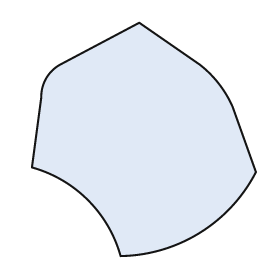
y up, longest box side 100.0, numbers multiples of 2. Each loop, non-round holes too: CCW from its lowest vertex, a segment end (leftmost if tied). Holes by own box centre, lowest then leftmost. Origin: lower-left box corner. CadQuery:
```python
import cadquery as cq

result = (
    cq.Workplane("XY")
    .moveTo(38.0, 0.0)
    .threePointArc((72.0, 10.0), (96.0, 36.0))
    .lineTo(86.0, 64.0)
    .threePointArc((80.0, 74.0), (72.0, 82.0))
    .lineTo(46.0, 100.0)
    .lineTo(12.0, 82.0)
    .threePointArc((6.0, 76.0), (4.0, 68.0))
    .lineTo(0.0, 38.0)
    .threePointArc((24.0, 24.0), (38.0, 0.0))
    .close()
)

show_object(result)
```